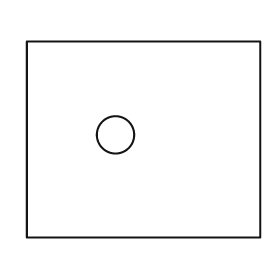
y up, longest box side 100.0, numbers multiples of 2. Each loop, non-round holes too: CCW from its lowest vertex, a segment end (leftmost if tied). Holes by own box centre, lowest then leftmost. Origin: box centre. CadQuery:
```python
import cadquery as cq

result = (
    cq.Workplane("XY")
    .moveTo(-50.0, -42.0)
    .lineTo(50.0, -42.0)
    .lineTo(50.0, 42.0)
    .lineTo(-50.0, 42.0)
    .close()
    .moveTo(-12.0, 2.0)
    .circle(8.0)
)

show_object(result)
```